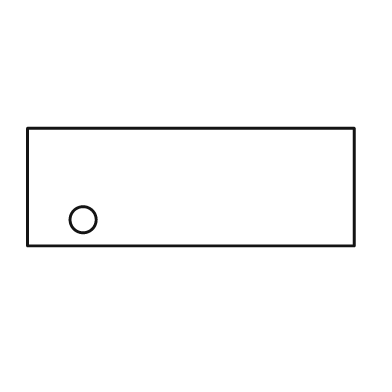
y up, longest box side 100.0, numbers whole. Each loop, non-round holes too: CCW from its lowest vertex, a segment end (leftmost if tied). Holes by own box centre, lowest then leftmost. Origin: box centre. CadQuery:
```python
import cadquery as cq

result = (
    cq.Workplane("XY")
    .moveTo(-50.0, -18.0)
    .lineTo(50.0, -18.0)
    .lineTo(50.0, 18.0)
    .lineTo(-50.0, 18.0)
    .close()
    .moveTo(-33.0, -10.0)
    .circle(4.0)
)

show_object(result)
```